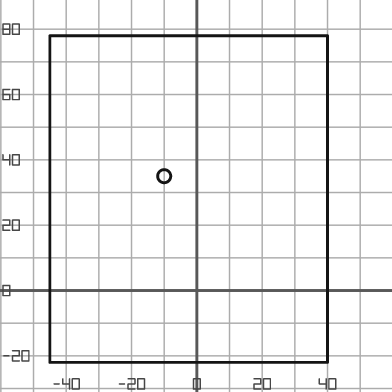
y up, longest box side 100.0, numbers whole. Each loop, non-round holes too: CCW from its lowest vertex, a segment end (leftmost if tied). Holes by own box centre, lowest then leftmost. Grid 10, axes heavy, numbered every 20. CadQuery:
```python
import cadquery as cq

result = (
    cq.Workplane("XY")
    .moveTo(-45.0, -22.0)
    .lineTo(40.0, -22.0)
    .lineTo(40.0, 78.0)
    .lineTo(-45.0, 78.0)
    .close()
    .moveTo(-10.0, 35.0)
    .circle(2.0)
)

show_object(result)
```